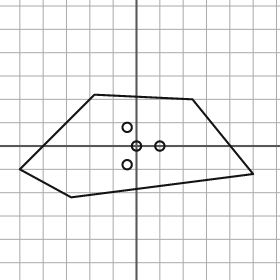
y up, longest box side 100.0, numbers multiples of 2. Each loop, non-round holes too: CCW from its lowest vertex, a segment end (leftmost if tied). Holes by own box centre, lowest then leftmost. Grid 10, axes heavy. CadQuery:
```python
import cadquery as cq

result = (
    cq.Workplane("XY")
    .moveTo(-28.0, -22.0)
    .lineTo(50.0, -12.0)
    .lineTo(24.0, 20.0)
    .lineTo(-18.0, 22.0)
    .lineTo(-50.0, -10.0)
    .close()
    .moveTo(-4.0, -8.0)
    .circle(2.0)
    .moveTo(0.0, 0.0)
    .circle(2.0)
    .moveTo(10.0, 0.0)
    .circle(2.0)
    .moveTo(-4.0, 8.0)
    .circle(2.0)
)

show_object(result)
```